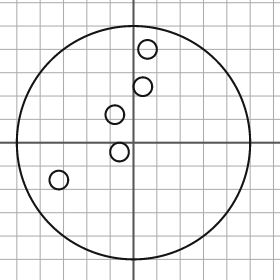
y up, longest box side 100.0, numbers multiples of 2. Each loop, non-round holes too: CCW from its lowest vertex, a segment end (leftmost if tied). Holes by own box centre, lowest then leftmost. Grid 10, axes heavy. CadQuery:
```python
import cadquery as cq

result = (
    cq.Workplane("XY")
    .moveTo(0.0, 0.0)
    .circle(50.0)
    .moveTo(-32.0, -16.0)
    .circle(4.0)
    .moveTo(-6.0, -4.0)
    .circle(4.0)
    .moveTo(-8.0, 12.0)
    .circle(4.0)
    .moveTo(4.0, 24.0)
    .circle(4.0)
    .moveTo(6.0, 40.0)
    .circle(4.0)
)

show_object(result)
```